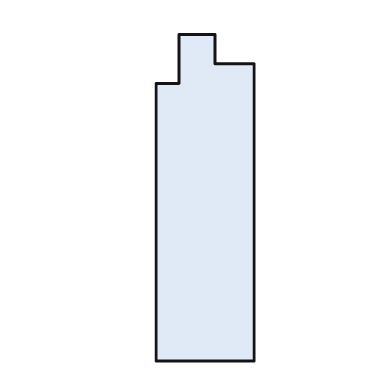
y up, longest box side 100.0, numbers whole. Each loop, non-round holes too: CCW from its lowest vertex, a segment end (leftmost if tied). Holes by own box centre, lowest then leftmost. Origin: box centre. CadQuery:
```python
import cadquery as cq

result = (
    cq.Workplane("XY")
    .moveTo(-15.0, -50.0)
    .lineTo(15.0, -50.0)
    .lineTo(15.0, 41.0)
    .lineTo(3.0, 41.0)
    .lineTo(3.0, 50.0)
    .lineTo(-8.0, 50.0)
    .lineTo(-8.0, 35.0)
    .lineTo(-15.0, 35.0)
    .close()
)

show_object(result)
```